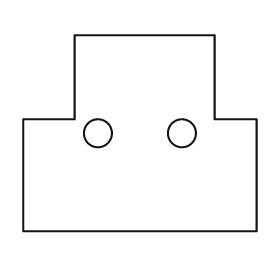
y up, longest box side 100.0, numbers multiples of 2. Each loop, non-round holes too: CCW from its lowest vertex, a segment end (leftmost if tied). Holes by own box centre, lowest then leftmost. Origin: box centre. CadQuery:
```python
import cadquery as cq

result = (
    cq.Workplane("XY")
    .moveTo(-50.0, -42.0)
    .lineTo(50.0, -42.0)
    .lineTo(50.0, 6.0)
    .lineTo(32.0, 6.0)
    .lineTo(32.0, 42.0)
    .lineTo(-28.0, 42.0)
    .lineTo(-28.0, 6.0)
    .lineTo(-50.0, 6.0)
    .close()
    .moveTo(-18.0, 0.0)
    .circle(6.0)
    .moveTo(18.0, 0.0)
    .circle(6.0)
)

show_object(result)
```